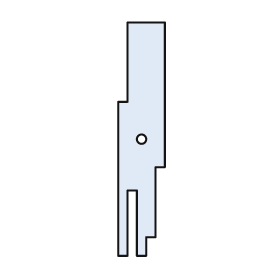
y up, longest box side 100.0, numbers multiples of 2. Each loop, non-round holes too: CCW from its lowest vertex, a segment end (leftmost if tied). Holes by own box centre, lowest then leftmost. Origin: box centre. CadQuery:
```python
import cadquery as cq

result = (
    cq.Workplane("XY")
    .moveTo(-10.0, -50.0)
    .lineTo(-6.0, -50.0)
    .lineTo(-6.0, -22.0)
    .lineTo(-2.0, -22.0)
    .lineTo(-2.0, -50.0)
    .lineTo(2.0, -50.0)
    .lineTo(2.0, -42.0)
    .lineTo(6.0, -42.0)
    .lineTo(6.0, -12.0)
    .lineTo(10.0, -12.0)
    .lineTo(10.0, 50.0)
    .lineTo(-6.0, 50.0)
    .lineTo(-6.0, 16.0)
    .lineTo(-10.0, 16.0)
    .close()
    .moveTo(0.0, 0.0)
    .circle(2.0)
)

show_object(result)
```